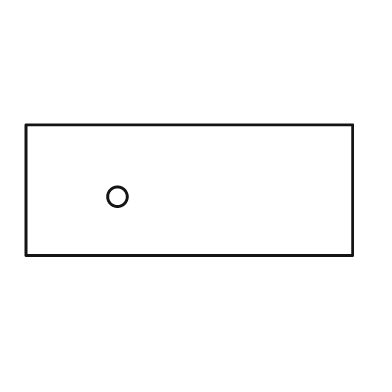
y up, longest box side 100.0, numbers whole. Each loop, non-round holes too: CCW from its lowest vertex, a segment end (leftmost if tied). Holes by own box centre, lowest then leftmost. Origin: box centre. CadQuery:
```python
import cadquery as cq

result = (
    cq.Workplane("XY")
    .moveTo(-50.0, -20.0)
    .lineTo(50.0, -20.0)
    .lineTo(50.0, 20.0)
    .lineTo(-50.0, 20.0)
    .close()
    .moveTo(-22.0, -2.0)
    .circle(3.0)
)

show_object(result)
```